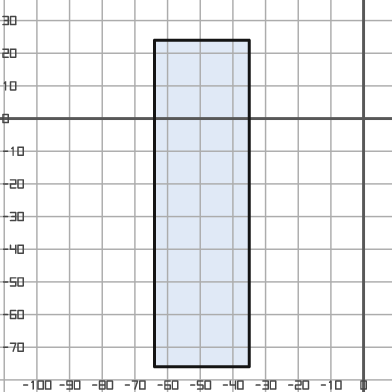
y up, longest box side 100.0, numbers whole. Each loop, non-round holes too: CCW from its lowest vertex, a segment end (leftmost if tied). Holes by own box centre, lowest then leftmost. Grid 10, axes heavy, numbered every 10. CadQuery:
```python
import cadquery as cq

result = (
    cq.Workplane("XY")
    .moveTo(-64.0, -76.0)
    .lineTo(-35.0, -76.0)
    .lineTo(-35.0, 24.0)
    .lineTo(-64.0, 24.0)
    .close()
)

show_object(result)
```